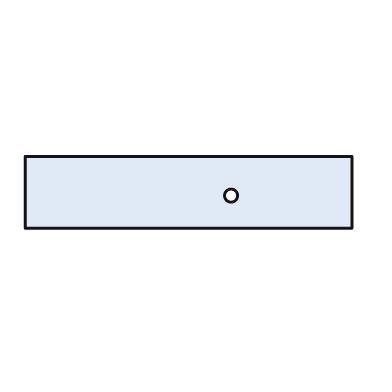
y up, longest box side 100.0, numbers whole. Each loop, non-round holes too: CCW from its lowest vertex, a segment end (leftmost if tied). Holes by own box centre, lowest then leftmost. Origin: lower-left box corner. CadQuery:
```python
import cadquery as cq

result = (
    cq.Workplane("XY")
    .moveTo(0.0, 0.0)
    .lineTo(100.0, 0.0)
    .lineTo(100.0, 22.0)
    .lineTo(0.0, 22.0)
    .close()
    .moveTo(63.0, 10.0)
    .circle(2.0)
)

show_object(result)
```